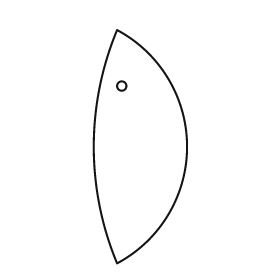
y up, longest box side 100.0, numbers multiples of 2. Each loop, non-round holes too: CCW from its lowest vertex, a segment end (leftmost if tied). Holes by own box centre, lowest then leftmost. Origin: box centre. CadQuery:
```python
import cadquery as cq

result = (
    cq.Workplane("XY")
    .moveTo(-10.0, -50.0)
    .threePointArc((20.0, 0.0), (-10.0, 50.0))
    .threePointArc((-20.0, 0.0), (-10.0, -50.0))
    .close()
    .moveTo(-8.0, 26.0)
    .circle(2.0)
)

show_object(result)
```